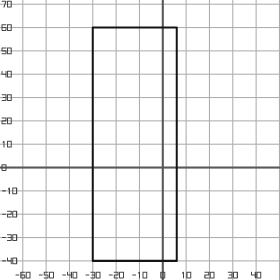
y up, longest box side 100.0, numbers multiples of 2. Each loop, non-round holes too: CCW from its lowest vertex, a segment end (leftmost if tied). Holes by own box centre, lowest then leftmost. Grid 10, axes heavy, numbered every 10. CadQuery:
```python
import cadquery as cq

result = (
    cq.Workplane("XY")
    .moveTo(-30.0, -40.0)
    .lineTo(6.0, -40.0)
    .lineTo(6.0, 60.0)
    .lineTo(-30.0, 60.0)
    .close()
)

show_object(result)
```